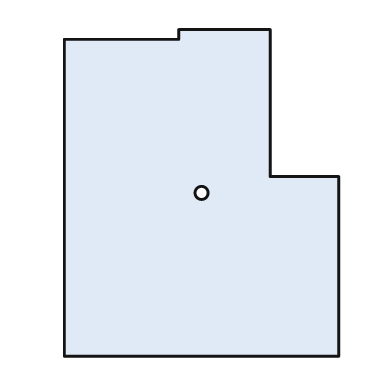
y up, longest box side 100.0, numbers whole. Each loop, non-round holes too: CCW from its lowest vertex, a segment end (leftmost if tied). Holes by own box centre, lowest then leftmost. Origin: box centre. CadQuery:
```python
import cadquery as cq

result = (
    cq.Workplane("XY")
    .moveTo(-42.0, -50.0)
    .lineTo(42.0, -50.0)
    .lineTo(42.0, 5.0)
    .lineTo(21.0, 5.0)
    .lineTo(21.0, 50.0)
    .lineTo(-7.0, 50.0)
    .lineTo(-7.0, 47.0)
    .lineTo(-42.0, 47.0)
    .close()
    .moveTo(0.0, 0.0)
    .circle(2.0)
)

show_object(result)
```